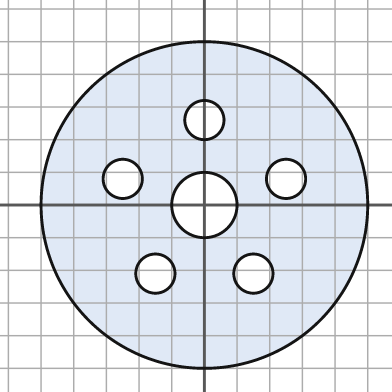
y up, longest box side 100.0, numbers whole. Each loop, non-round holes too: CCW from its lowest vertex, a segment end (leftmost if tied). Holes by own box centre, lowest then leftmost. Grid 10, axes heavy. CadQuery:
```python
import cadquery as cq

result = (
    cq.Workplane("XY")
    .moveTo(0.0, 0.0)
    .circle(50.0)
    .moveTo(-15.0, -21.0)
    .circle(6.0)
    .moveTo(15.0, -21.0)
    .circle(6.0)
    .moveTo(0.0, 0.0)
    .circle(10.0)
    .moveTo(-25.0, 8.0)
    .circle(6.0)
    .moveTo(25.0, 8.0)
    .circle(6.0)
    .moveTo(0.0, 26.0)
    .circle(6.0)
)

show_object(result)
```